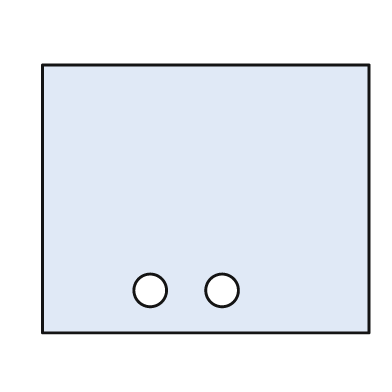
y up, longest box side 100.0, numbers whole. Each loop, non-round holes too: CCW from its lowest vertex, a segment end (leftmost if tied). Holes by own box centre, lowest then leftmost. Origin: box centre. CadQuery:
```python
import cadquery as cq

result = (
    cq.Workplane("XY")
    .moveTo(-50.0, -41.0)
    .lineTo(50.0, -41.0)
    .lineTo(50.0, 41.0)
    .lineTo(-50.0, 41.0)
    .close()
    .moveTo(-17.0, -28.0)
    .circle(5.0)
    .moveTo(5.0, -28.0)
    .circle(5.0)
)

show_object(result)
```